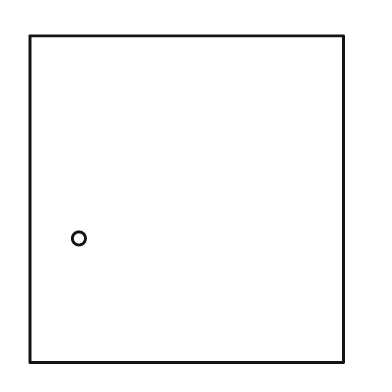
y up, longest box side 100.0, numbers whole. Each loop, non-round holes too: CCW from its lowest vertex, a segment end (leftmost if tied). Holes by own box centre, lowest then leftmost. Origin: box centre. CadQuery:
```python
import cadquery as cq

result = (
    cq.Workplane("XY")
    .moveTo(-48.0, -50.0)
    .lineTo(48.0, -50.0)
    .lineTo(48.0, 50.0)
    .lineTo(-48.0, 50.0)
    .close()
    .moveTo(-33.0, -12.0)
    .circle(2.0)
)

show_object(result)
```